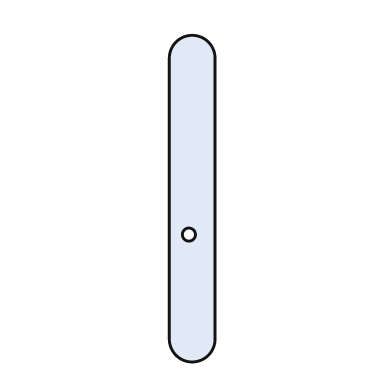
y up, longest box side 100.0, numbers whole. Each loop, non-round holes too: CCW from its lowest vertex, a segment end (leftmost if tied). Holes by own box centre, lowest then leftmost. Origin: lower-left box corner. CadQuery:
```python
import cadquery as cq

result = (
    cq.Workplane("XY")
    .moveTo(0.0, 7.0)
    .threePointArc((7.0, 0.0), (14.0, 7.0))
    .lineTo(14.0, 93.0)
    .threePointArc((7.0, 100.0), (0.0, 93.0))
    .close()
    .moveTo(6.0, 39.0)
    .circle(2.0)
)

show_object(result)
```